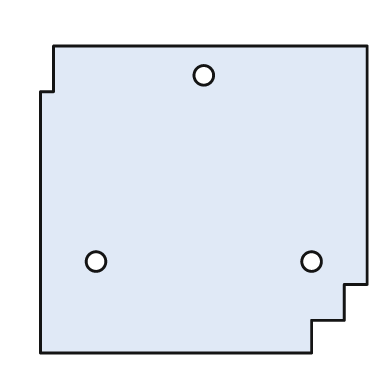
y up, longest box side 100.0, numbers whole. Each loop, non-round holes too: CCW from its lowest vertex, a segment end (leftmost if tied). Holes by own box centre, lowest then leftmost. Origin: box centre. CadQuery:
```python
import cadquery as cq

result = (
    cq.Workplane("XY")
    .moveTo(-50.0, -47.0)
    .lineTo(33.0, -47.0)
    .lineTo(33.0, -37.0)
    .lineTo(43.0, -37.0)
    .lineTo(43.0, -26.0)
    .lineTo(50.0, -26.0)
    .lineTo(50.0, 47.0)
    .lineTo(-46.0, 47.0)
    .lineTo(-46.0, 33.0)
    .lineTo(-50.0, 33.0)
    .close()
    .moveTo(-33.0, -19.0)
    .circle(3.0)
    .moveTo(33.0, -19.0)
    .circle(3.0)
    .moveTo(0.0, 38.0)
    .circle(3.0)
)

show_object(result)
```